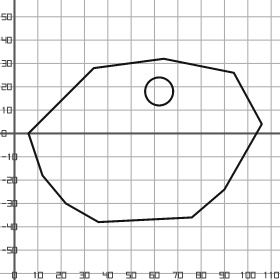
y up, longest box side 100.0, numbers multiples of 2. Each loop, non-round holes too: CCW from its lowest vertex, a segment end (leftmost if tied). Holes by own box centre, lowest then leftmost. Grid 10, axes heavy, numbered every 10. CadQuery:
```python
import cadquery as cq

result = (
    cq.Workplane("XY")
    .moveTo(36.0, -38.0)
    .lineTo(76.0, -36.0)
    .lineTo(90.0, -24.0)
    .lineTo(106.0, 4.0)
    .lineTo(94.0, 26.0)
    .lineTo(64.0, 32.0)
    .lineTo(34.0, 28.0)
    .lineTo(6.0, 0.0)
    .lineTo(12.0, -18.0)
    .lineTo(22.0, -30.0)
    .close()
    .moveTo(62.0, 18.0)
    .circle(6.0)
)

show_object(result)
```